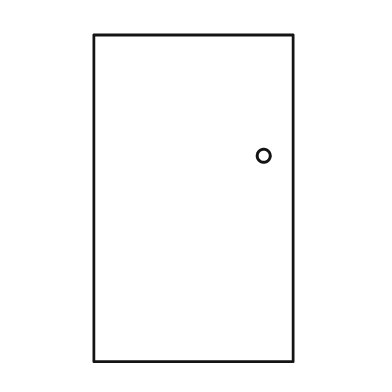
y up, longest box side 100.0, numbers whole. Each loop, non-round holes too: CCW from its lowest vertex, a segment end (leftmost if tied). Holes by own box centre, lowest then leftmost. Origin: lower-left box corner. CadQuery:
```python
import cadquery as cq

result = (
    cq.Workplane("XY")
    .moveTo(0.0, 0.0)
    .lineTo(61.0, 0.0)
    .lineTo(61.0, 100.0)
    .lineTo(0.0, 100.0)
    .close()
    .moveTo(52.0, 63.0)
    .circle(2.0)
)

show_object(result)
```